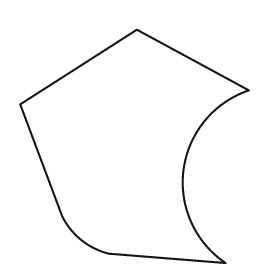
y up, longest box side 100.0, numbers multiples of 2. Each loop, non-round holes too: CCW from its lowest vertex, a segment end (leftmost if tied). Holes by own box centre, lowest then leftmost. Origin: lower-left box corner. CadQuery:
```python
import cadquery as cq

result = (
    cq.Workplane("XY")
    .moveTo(88.0, 0.0)
    .threePointArc((70.0, 40.0), (98.0, 74.0))
    .lineTo(50.0, 100.0)
    .lineTo(0.0, 68.0)
    .lineTo(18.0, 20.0)
    .threePointArc((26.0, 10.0), (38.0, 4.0))
    .close()
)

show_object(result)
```